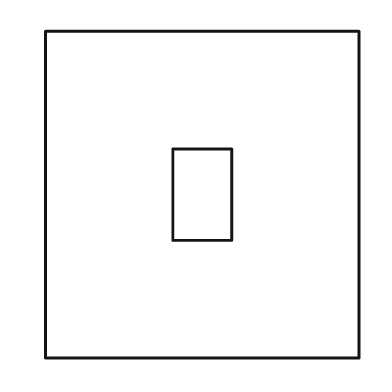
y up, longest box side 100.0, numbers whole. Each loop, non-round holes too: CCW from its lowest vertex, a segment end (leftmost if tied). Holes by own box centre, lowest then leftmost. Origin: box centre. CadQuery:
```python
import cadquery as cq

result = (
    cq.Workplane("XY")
    .moveTo(-48.0, -50.0)
    .lineTo(48.0, -50.0)
    .lineTo(48.0, 50.0)
    .lineTo(-48.0, 50.0)
    .close()
    .moveTo(-9.0, -14.0)
    .lineTo(9.0, -14.0)
    .lineTo(9.0, 14.0)
    .lineTo(-9.0, 14.0)
    .close()
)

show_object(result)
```